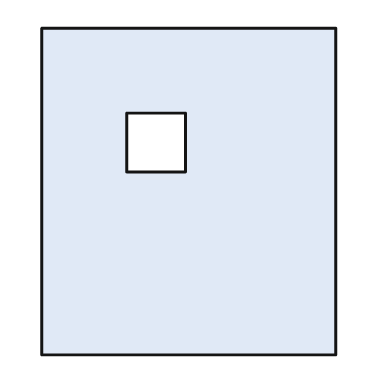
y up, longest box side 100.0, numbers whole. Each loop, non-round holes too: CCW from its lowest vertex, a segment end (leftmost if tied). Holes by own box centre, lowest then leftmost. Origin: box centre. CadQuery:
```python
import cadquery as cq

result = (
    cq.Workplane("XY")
    .moveTo(-45.0, -50.0)
    .lineTo(45.0, -50.0)
    .lineTo(45.0, 50.0)
    .lineTo(-45.0, 50.0)
    .close()
    .moveTo(-19.0, 6.0)
    .lineTo(-1.0, 6.0)
    .lineTo(-1.0, 24.0)
    .lineTo(-19.0, 24.0)
    .close()
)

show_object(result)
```